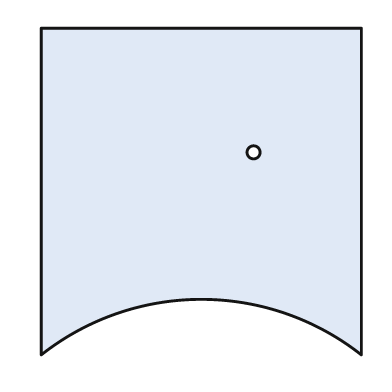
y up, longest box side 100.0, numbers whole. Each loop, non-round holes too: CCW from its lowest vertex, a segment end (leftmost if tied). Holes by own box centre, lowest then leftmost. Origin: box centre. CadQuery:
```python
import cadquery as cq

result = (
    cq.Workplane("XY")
    .moveTo(-49.0, -50.0)
    .threePointArc((0.0, -33.0), (49.0, -50.0))
    .lineTo(49.0, 50.0)
    .lineTo(-49.0, 50.0)
    .close()
    .moveTo(16.0, 12.0)
    .circle(2.0)
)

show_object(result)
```